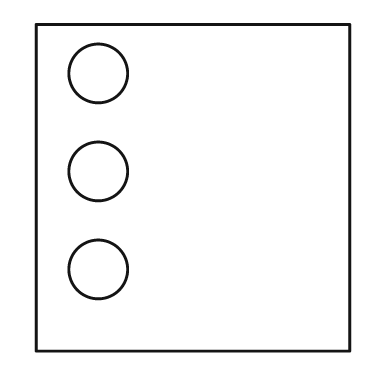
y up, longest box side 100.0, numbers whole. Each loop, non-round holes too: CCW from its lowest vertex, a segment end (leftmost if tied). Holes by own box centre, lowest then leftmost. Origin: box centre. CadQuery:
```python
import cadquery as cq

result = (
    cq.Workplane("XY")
    .moveTo(-48.0, -50.0)
    .lineTo(48.0, -50.0)
    .lineTo(48.0, 50.0)
    .lineTo(-48.0, 50.0)
    .close()
    .moveTo(-29.0, -25.0)
    .circle(9.0)
    .moveTo(-29.0, 5.0)
    .circle(9.0)
    .moveTo(-29.0, 35.0)
    .circle(9.0)
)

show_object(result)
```